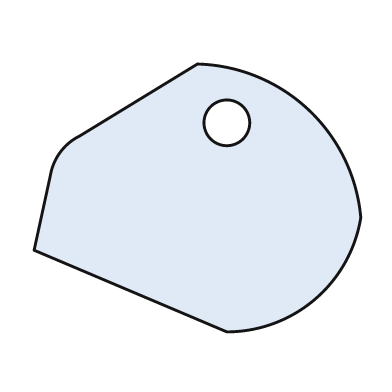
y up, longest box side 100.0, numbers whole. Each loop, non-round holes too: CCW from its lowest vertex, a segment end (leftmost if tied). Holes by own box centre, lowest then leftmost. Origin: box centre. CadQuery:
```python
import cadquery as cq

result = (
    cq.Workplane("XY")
    .moveTo(9.0, -41.0)
    .threePointArc((36.0, -31.0), (50.0, -6.0))
    .threePointArc((34.0, 27.0), (0.0, 41.0))
    .lineTo(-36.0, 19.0)
    .threePointArc((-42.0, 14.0), (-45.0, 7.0))
    .lineTo(-50.0, -16.0)
    .close()
    .moveTo(9.0, 23.0)
    .circle(7.0)
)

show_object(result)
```